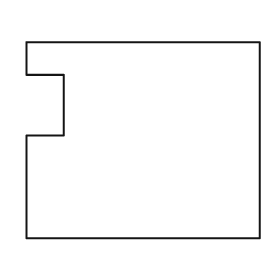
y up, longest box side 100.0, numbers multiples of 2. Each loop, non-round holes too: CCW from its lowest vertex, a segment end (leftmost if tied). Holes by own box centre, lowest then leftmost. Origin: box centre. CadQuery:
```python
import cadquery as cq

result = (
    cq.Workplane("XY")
    .moveTo(-50.0, -42.0)
    .lineTo(50.0, -42.0)
    .lineTo(50.0, 42.0)
    .lineTo(-50.0, 42.0)
    .lineTo(-50.0, 28.0)
    .lineTo(-34.0, 28.0)
    .lineTo(-34.0, 2.0)
    .lineTo(-50.0, 2.0)
    .close()
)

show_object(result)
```